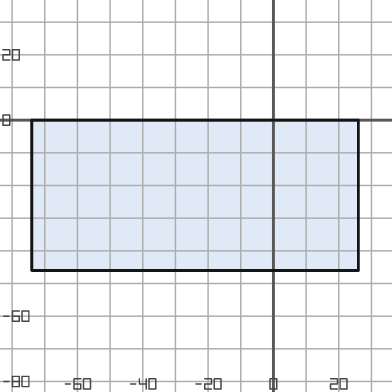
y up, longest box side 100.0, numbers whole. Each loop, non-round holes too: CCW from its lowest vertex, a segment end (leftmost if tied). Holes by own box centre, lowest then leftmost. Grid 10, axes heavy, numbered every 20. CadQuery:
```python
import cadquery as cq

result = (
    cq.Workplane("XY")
    .moveTo(-74.0, -46.0)
    .lineTo(26.0, -46.0)
    .lineTo(26.0, 0.0)
    .lineTo(-74.0, 0.0)
    .close()
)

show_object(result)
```